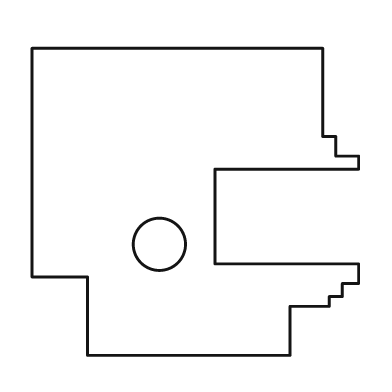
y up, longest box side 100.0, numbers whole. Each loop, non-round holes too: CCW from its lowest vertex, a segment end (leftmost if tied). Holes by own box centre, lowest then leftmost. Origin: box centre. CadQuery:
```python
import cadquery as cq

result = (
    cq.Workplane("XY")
    .moveTo(-33.0, -47.0)
    .lineTo(29.0, -47.0)
    .lineTo(29.0, -32.0)
    .lineTo(41.0, -32.0)
    .lineTo(41.0, -29.0)
    .lineTo(45.0, -29.0)
    .lineTo(45.0, -25.0)
    .lineTo(50.0, -25.0)
    .lineTo(50.0, -19.0)
    .lineTo(6.0, -19.0)
    .lineTo(6.0, 10.0)
    .lineTo(50.0, 10.0)
    .lineTo(50.0, 14.0)
    .lineTo(43.0, 14.0)
    .lineTo(43.0, 20.0)
    .lineTo(39.0, 20.0)
    .lineTo(39.0, 47.0)
    .lineTo(-50.0, 47.0)
    .lineTo(-50.0, -23.0)
    .lineTo(-33.0, -23.0)
    .close()
    .moveTo(-11.0, -13.0)
    .circle(8.0)
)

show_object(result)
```